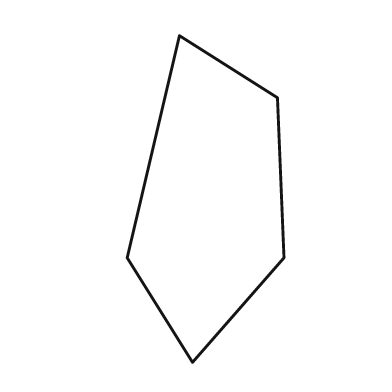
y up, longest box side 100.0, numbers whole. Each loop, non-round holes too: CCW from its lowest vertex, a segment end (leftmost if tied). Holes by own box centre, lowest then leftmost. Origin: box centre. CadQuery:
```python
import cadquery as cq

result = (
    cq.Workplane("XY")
    .moveTo(-4.0, -50.0)
    .lineTo(24.0, -18.0)
    .lineTo(22.0, 31.0)
    .lineTo(-8.0, 50.0)
    .lineTo(-24.0, -18.0)
    .close()
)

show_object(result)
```